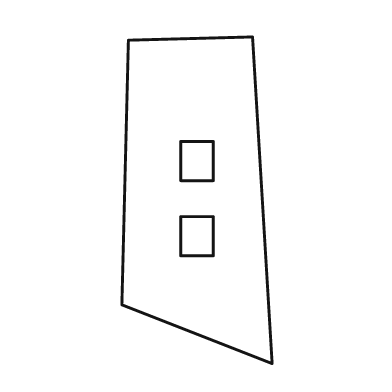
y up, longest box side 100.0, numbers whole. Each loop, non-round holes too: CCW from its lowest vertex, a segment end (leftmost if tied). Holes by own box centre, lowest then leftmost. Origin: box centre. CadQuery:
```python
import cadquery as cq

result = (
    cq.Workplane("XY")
    .moveTo(23.0, -50.0)
    .lineTo(17.0, 50.0)
    .lineTo(-21.0, 49.0)
    .lineTo(-23.0, -32.0)
    .close()
    .moveTo(-5.0, -17.0)
    .lineTo(5.0, -17.0)
    .lineTo(5.0, -5.0)
    .lineTo(-5.0, -5.0)
    .close()
    .moveTo(-5.0, 6.0)
    .lineTo(5.0, 6.0)
    .lineTo(5.0, 18.0)
    .lineTo(-5.0, 18.0)
    .close()
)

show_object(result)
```